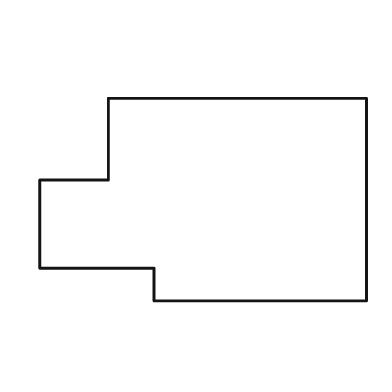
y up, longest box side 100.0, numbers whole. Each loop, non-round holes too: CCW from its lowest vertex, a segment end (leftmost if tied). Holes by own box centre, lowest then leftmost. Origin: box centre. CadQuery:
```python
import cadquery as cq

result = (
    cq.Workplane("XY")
    .moveTo(-15.0, -31.0)
    .lineTo(50.0, -31.0)
    .lineTo(50.0, 31.0)
    .lineTo(-29.0, 31.0)
    .lineTo(-29.0, 6.0)
    .lineTo(-50.0, 6.0)
    .lineTo(-50.0, -21.0)
    .lineTo(-15.0, -21.0)
    .close()
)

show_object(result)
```